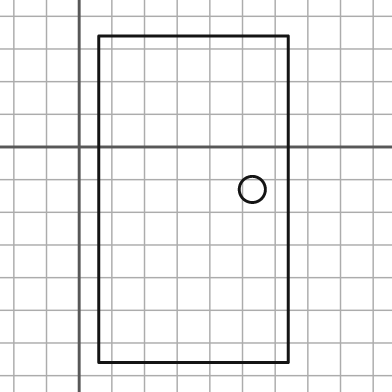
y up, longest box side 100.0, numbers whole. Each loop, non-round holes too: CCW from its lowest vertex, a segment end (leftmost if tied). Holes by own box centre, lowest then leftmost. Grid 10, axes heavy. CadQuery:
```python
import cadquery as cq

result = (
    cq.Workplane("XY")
    .moveTo(6.0, -66.0)
    .lineTo(64.0, -66.0)
    .lineTo(64.0, 34.0)
    .lineTo(6.0, 34.0)
    .close()
    .moveTo(53.0, -13.0)
    .circle(4.0)
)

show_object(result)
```